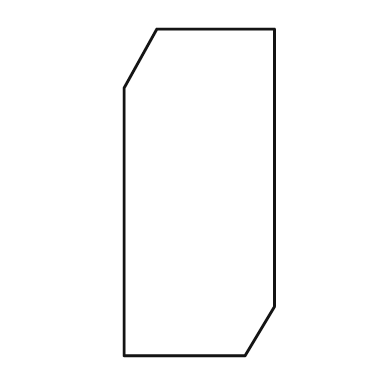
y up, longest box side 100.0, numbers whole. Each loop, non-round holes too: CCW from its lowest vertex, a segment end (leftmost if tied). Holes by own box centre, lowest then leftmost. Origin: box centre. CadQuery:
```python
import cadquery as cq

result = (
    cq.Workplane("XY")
    .moveTo(-23.0, -50.0)
    .lineTo(14.0, -50.0)
    .lineTo(23.0, -35.0)
    .lineTo(23.0, 50.0)
    .lineTo(-13.0, 50.0)
    .lineTo(-23.0, 32.0)
    .close()
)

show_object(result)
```